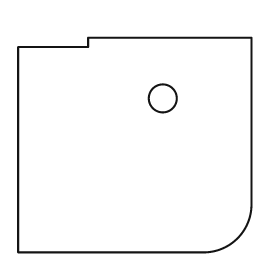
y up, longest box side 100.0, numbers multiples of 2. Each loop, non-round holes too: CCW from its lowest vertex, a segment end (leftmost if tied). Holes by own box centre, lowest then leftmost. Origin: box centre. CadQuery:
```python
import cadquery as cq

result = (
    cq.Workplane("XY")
    .moveTo(-50.0, -46.0)
    .lineTo(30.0, -46.0)
    .threePointArc((44.0, -40.0), (50.0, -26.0))
    .lineTo(50.0, 46.0)
    .lineTo(-20.0, 46.0)
    .lineTo(-20.0, 42.0)
    .lineTo(-50.0, 42.0)
    .close()
    .moveTo(12.0, 20.0)
    .circle(6.0)
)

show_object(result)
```